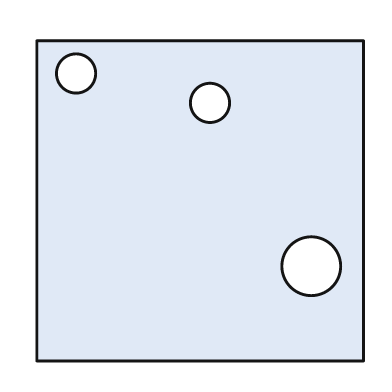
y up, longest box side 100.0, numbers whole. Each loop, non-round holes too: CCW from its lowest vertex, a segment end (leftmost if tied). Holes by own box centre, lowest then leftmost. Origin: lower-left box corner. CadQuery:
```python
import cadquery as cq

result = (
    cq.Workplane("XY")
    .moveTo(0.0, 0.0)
    .lineTo(100.0, 0.0)
    .lineTo(100.0, 98.0)
    .lineTo(0.0, 98.0)
    .close()
    .moveTo(84.0, 29.0)
    .circle(9.0)
    .moveTo(53.0, 79.0)
    .circle(6.0)
    .moveTo(12.0, 88.0)
    .circle(6.0)
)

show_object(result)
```